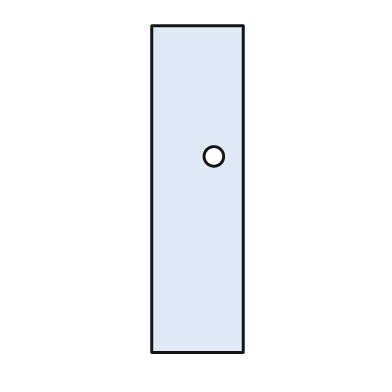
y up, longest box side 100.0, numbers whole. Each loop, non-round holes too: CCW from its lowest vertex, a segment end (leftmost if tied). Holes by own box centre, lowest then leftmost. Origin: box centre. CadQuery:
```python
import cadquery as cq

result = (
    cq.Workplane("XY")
    .moveTo(-14.0, -50.0)
    .lineTo(14.0, -50.0)
    .lineTo(14.0, 50.0)
    .lineTo(-14.0, 50.0)
    .close()
    .moveTo(5.0, 10.0)
    .circle(3.0)
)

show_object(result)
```